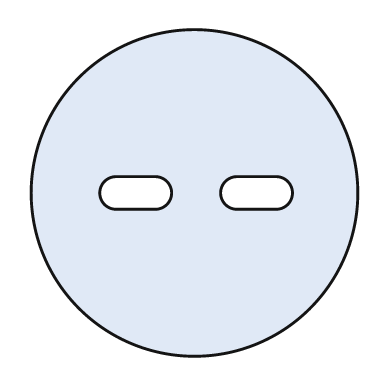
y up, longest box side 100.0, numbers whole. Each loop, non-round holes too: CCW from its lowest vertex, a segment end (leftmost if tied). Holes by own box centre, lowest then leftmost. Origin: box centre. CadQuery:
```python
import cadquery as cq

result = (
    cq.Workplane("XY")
    .moveTo(0.0, 0.0)
    .circle(50.0)
    .moveTo(-24.0, -5.0)
    .lineTo(-12.0, -5.0)
    .threePointArc((-7.0, 0.0), (-12.0, 5.0))
    .lineTo(-24.0, 5.0)
    .threePointArc((-29.0, 0.0), (-24.0, -5.0))
    .close()
    .moveTo(13.0, -5.0)
    .lineTo(25.0, -5.0)
    .threePointArc((30.0, 0.0), (25.0, 5.0))
    .lineTo(13.0, 5.0)
    .threePointArc((8.0, 0.0), (13.0, -5.0))
    .close()
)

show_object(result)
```